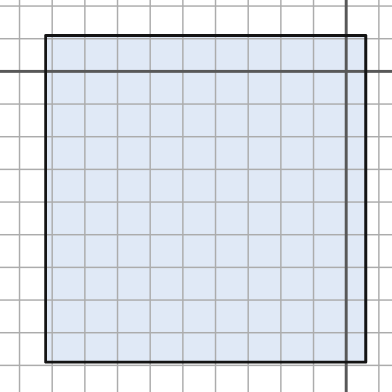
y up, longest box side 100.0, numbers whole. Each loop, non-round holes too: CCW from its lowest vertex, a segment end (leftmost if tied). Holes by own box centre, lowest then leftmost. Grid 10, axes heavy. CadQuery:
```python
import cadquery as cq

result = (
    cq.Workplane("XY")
    .moveTo(-92.0, -89.0)
    .lineTo(6.0, -89.0)
    .lineTo(6.0, 11.0)
    .lineTo(-92.0, 11.0)
    .close()
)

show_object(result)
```